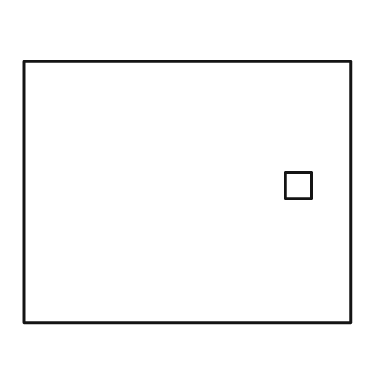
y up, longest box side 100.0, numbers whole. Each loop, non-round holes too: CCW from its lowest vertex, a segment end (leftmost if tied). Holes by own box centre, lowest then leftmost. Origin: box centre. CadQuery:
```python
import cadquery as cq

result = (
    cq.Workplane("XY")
    .moveTo(-50.0, -40.0)
    .lineTo(50.0, -40.0)
    .lineTo(50.0, 40.0)
    .lineTo(-50.0, 40.0)
    .close()
    .moveTo(30.0, -2.0)
    .lineTo(38.0, -2.0)
    .lineTo(38.0, 6.0)
    .lineTo(30.0, 6.0)
    .close()
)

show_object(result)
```